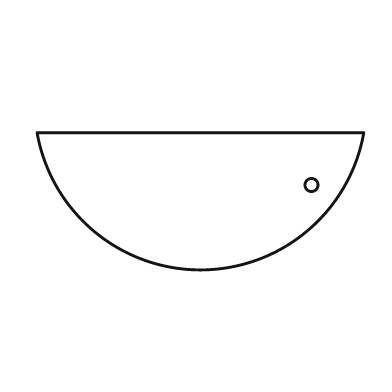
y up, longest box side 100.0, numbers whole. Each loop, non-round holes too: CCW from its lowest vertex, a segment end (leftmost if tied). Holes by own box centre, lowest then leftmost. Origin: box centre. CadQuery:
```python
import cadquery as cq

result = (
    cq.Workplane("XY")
    .moveTo(-50.0, 21.0)
    .threePointArc((0.0, -21.0), (50.0, 21.0))
    .close()
    .moveTo(34.0, 5.0)
    .circle(2.0)
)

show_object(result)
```